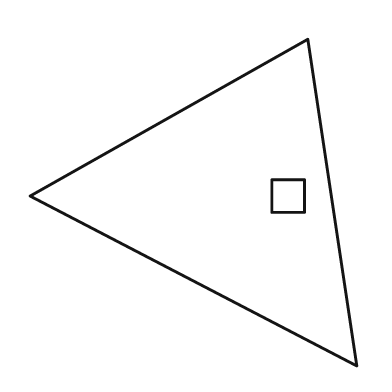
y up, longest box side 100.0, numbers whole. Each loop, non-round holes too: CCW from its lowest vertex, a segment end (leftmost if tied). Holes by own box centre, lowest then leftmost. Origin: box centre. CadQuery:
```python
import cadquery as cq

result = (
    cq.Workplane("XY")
    .moveTo(50.0, -50.0)
    .lineTo(35.0, 50.0)
    .lineTo(-50.0, 2.0)
    .close()
    .moveTo(24.0, -3.0)
    .lineTo(34.0, -3.0)
    .lineTo(34.0, 7.0)
    .lineTo(24.0, 7.0)
    .close()
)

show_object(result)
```